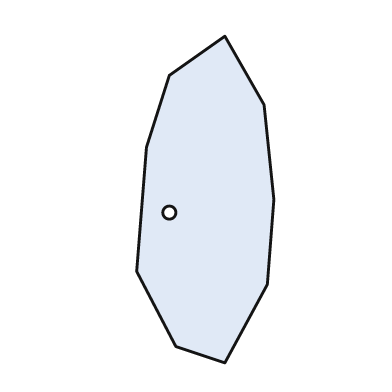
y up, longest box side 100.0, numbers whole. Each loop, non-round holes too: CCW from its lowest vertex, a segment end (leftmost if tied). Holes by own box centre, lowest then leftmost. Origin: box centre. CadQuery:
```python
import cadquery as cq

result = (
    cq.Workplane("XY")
    .moveTo(6.0, -50.0)
    .lineTo(19.0, -26.0)
    .lineTo(21.0, 0.0)
    .lineTo(18.0, 29.0)
    .lineTo(6.0, 50.0)
    .lineTo(-11.0, 38.0)
    .lineTo(-18.0, 16.0)
    .lineTo(-21.0, -22.0)
    .lineTo(-9.0, -45.0)
    .close()
    .moveTo(-11.0, -4.0)
    .circle(2.0)
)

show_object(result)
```